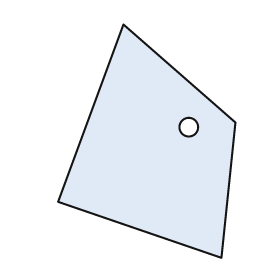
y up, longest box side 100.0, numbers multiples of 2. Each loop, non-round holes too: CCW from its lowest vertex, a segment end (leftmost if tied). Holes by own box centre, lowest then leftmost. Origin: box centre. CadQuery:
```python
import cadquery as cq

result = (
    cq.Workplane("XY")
    .moveTo(32.0, -50.0)
    .lineTo(38.0, 8.0)
    .lineTo(-10.0, 50.0)
    .lineTo(-38.0, -26.0)
    .close()
    .moveTo(18.0, 6.0)
    .circle(4.0)
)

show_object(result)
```